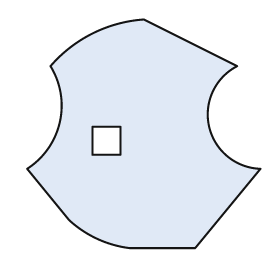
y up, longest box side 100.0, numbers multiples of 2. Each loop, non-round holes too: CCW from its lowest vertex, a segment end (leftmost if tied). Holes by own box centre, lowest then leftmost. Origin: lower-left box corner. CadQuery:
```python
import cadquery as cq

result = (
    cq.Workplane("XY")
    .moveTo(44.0, 0.0)
    .lineTo(72.0, 0.0)
    .lineTo(100.0, 34.0)
    .threePointArc((78.0, 52.0), (90.0, 78.0))
    .lineTo(50.0, 98.0)
    .threePointArc((28.0, 92.0), (10.0, 78.0))
    .threePointArc((14.0, 54.0), (0.0, 34.0))
    .lineTo(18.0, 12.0)
    .threePointArc((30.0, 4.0), (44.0, 0.0))
    .close()
    .moveTo(28.0, 40.0)
    .lineTo(40.0, 40.0)
    .lineTo(40.0, 52.0)
    .lineTo(28.0, 52.0)
    .close()
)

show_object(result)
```